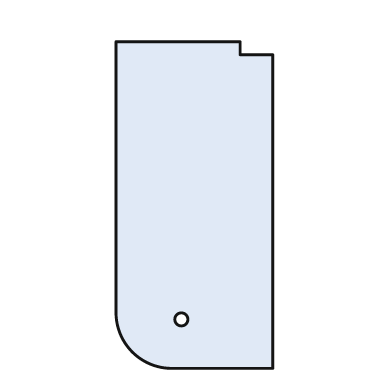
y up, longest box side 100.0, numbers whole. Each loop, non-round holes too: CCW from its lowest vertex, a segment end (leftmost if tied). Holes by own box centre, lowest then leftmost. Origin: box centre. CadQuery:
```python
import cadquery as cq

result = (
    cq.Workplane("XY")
    .moveTo(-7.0, -50.0)
    .lineTo(24.0, -50.0)
    .lineTo(24.0, 46.0)
    .lineTo(14.0, 46.0)
    .lineTo(14.0, 50.0)
    .lineTo(-24.0, 50.0)
    .lineTo(-24.0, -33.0)
    .threePointArc((-19.0, -45.0), (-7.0, -50.0))
    .close()
    .moveTo(-4.0, -35.0)
    .circle(2.0)
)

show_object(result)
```